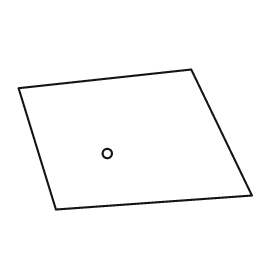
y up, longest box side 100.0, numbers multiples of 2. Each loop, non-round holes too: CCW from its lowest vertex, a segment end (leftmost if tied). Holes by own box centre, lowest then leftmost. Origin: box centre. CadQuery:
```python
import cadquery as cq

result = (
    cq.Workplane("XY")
    .moveTo(-34.0, -30.0)
    .lineTo(50.0, -24.0)
    .lineTo(24.0, 30.0)
    .lineTo(-50.0, 22.0)
    .close()
    .moveTo(-12.0, -6.0)
    .circle(2.0)
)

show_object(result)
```